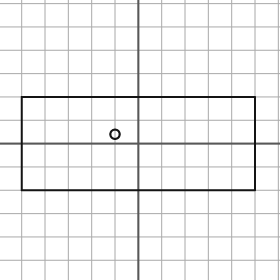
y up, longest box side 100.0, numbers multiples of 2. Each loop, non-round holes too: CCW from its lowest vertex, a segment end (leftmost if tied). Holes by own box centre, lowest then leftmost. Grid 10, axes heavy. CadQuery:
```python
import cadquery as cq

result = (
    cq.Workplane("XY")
    .moveTo(-50.0, -20.0)
    .lineTo(50.0, -20.0)
    .lineTo(50.0, 20.0)
    .lineTo(-50.0, 20.0)
    .close()
    .moveTo(-10.0, 4.0)
    .circle(2.0)
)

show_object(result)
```